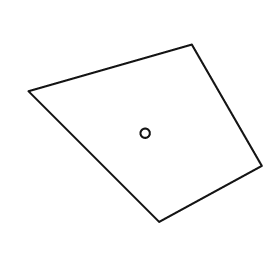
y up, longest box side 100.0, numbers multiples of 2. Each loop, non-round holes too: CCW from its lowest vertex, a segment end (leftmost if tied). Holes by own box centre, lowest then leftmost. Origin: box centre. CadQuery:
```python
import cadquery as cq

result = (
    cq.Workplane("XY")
    .moveTo(6.0, -38.0)
    .lineTo(50.0, -14.0)
    .lineTo(20.0, 38.0)
    .lineTo(-50.0, 18.0)
    .close()
    .moveTo(0.0, 0.0)
    .circle(2.0)
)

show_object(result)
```